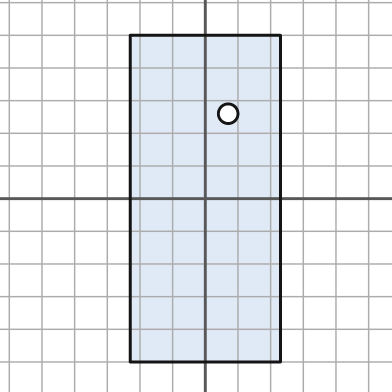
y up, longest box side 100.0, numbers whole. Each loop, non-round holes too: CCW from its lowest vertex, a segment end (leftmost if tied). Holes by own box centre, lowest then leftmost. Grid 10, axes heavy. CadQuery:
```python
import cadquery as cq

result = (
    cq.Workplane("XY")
    .moveTo(-23.0, -50.0)
    .lineTo(23.0, -50.0)
    .lineTo(23.0, 50.0)
    .lineTo(-23.0, 50.0)
    .close()
    .moveTo(7.0, 26.0)
    .circle(3.0)
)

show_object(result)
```